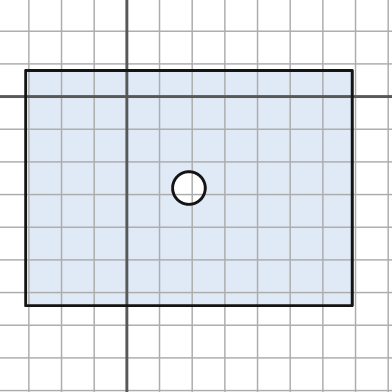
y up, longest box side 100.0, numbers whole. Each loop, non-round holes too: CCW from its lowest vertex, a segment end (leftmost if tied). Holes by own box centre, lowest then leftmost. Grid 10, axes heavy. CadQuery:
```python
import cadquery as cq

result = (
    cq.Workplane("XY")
    .moveTo(-31.0, -64.0)
    .lineTo(69.0, -64.0)
    .lineTo(69.0, 8.0)
    .lineTo(-31.0, 8.0)
    .close()
    .moveTo(19.0, -28.0)
    .circle(5.0)
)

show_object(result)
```